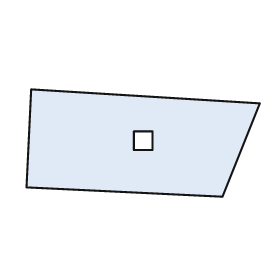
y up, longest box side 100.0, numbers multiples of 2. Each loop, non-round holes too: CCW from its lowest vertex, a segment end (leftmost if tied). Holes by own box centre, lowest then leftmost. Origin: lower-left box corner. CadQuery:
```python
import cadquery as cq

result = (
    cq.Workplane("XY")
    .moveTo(84.0, 0.0)
    .lineTo(100.0, 40.0)
    .lineTo(2.0, 46.0)
    .lineTo(0.0, 4.0)
    .close()
    .moveTo(46.0, 20.0)
    .lineTo(54.0, 20.0)
    .lineTo(54.0, 28.0)
    .lineTo(46.0, 28.0)
    .close()
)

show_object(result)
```